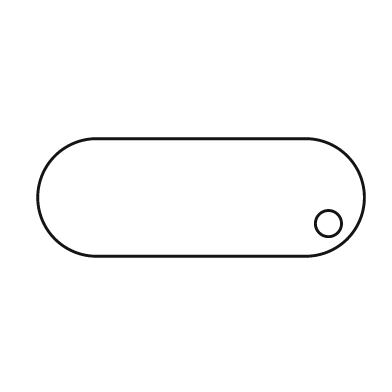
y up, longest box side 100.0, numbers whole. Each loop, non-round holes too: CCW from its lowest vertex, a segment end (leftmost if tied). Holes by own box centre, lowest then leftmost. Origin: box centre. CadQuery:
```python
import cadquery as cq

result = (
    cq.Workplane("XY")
    .moveTo(-32.0, -18.0)
    .lineTo(32.0, -18.0)
    .threePointArc((50.0, 0.0), (32.0, 18.0))
    .lineTo(-32.0, 18.0)
    .threePointArc((-50.0, 0.0), (-32.0, -18.0))
    .close()
    .moveTo(39.0, -8.0)
    .circle(4.0)
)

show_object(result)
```